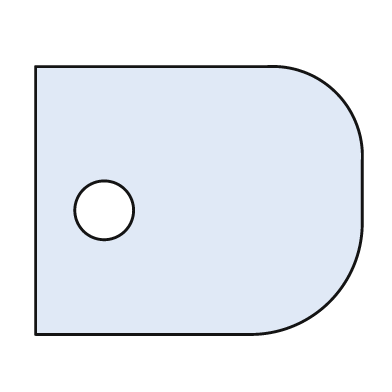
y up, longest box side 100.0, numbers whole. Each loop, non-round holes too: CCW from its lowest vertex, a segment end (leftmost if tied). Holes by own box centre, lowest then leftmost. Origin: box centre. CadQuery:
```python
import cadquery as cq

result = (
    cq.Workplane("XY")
    .moveTo(-50.0, -41.0)
    .lineTo(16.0, -41.0)
    .threePointArc((40.0, -31.0), (50.0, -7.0))
    .lineTo(50.0, 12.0)
    .threePointArc((42.0, 33.0), (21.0, 41.0))
    .lineTo(-50.0, 41.0)
    .close()
    .moveTo(-29.0, -3.0)
    .circle(9.0)
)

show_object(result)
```